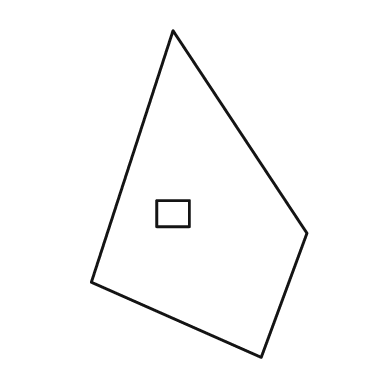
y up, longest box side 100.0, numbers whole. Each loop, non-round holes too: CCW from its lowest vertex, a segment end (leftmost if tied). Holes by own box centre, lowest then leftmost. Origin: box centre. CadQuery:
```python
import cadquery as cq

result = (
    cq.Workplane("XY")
    .moveTo(19.0, -50.0)
    .lineTo(33.0, -12.0)
    .lineTo(-8.0, 50.0)
    .lineTo(-33.0, -27.0)
    .close()
    .moveTo(-13.0, -10.0)
    .lineTo(-3.0, -10.0)
    .lineTo(-3.0, -2.0)
    .lineTo(-13.0, -2.0)
    .close()
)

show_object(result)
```